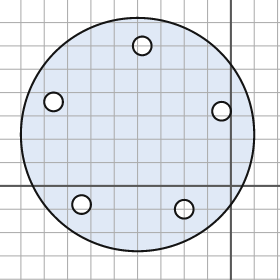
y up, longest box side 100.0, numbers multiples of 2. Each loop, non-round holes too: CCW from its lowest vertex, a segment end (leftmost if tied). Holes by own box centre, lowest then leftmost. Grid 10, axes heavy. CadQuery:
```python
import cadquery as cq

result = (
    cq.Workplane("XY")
    .moveTo(-40.0, 22.0)
    .circle(50.0)
    .moveTo(-20.0, -10.0)
    .circle(4.0)
    .moveTo(-64.0, -8.0)
    .circle(4.0)
    .moveTo(-4.0, 32.0)
    .circle(4.0)
    .moveTo(-76.0, 36.0)
    .circle(4.0)
    .moveTo(-38.0, 60.0)
    .circle(4.0)
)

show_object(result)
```